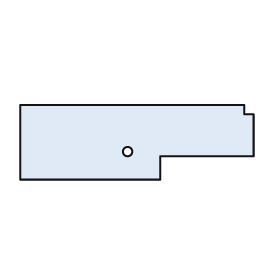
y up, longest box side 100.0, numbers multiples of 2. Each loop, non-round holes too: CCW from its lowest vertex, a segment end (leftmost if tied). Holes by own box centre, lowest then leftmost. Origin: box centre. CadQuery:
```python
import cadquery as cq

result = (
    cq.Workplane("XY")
    .moveTo(-50.0, -16.0)
    .lineTo(10.0, -16.0)
    .lineTo(10.0, -6.0)
    .lineTo(50.0, -6.0)
    .lineTo(50.0, 12.0)
    .lineTo(46.0, 12.0)
    .lineTo(46.0, 16.0)
    .lineTo(-50.0, 16.0)
    .close()
    .moveTo(-4.0, -4.0)
    .circle(2.0)
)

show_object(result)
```